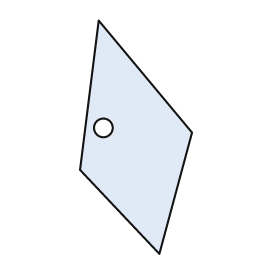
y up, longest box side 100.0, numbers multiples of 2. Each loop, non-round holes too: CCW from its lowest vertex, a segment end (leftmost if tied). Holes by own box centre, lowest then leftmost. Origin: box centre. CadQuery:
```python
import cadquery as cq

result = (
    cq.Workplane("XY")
    .moveTo(10.0, -50.0)
    .lineTo(24.0, 2.0)
    .lineTo(-16.0, 50.0)
    .lineTo(-24.0, -14.0)
    .close()
    .moveTo(-14.0, 4.0)
    .circle(4.0)
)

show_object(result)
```